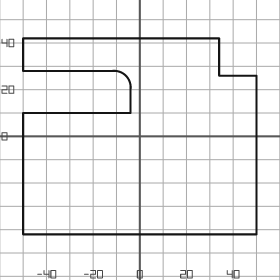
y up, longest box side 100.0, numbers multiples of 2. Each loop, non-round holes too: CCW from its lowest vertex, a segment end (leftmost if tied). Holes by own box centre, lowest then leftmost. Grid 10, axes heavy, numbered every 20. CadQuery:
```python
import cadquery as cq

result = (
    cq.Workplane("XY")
    .moveTo(-50.0, -42.0)
    .lineTo(50.0, -42.0)
    .lineTo(50.0, 26.0)
    .lineTo(34.0, 26.0)
    .lineTo(34.0, 42.0)
    .lineTo(-50.0, 42.0)
    .lineTo(-50.0, 28.0)
    .lineTo(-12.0, 28.0)
    .threePointArc((-6.0, 26.0), (-4.0, 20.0))
    .lineTo(-4.0, 10.0)
    .lineTo(-50.0, 10.0)
    .close()
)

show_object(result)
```